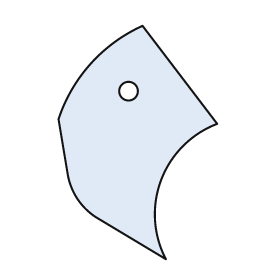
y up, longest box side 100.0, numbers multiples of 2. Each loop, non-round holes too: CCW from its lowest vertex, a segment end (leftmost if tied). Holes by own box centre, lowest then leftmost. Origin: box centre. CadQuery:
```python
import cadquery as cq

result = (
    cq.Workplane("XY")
    .moveTo(12.0, -50.0)
    .threePointArc((10.0, -16.0), (34.0, 8.0))
    .lineTo(2.0, 50.0)
    .threePointArc((-20.0, 34.0), (-34.0, 10.0))
    .lineTo(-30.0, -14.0)
    .threePointArc((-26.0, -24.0), (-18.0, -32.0))
    .close()
    .moveTo(-4.0, 22.0)
    .circle(4.0)
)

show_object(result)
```